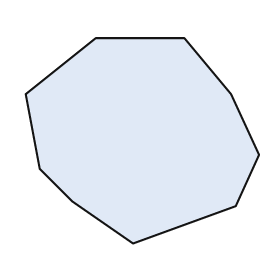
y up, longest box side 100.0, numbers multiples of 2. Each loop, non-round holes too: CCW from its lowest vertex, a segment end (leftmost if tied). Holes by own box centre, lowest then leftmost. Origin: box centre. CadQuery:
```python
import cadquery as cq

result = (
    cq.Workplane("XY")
    .moveTo(-4.0, -44.0)
    .lineTo(40.0, -28.0)
    .lineTo(50.0, -6.0)
    .lineTo(38.0, 20.0)
    .lineTo(18.0, 44.0)
    .lineTo(-20.0, 44.0)
    .lineTo(-50.0, 20.0)
    .lineTo(-44.0, -12.0)
    .lineTo(-30.0, -26.0)
    .close()
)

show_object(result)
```